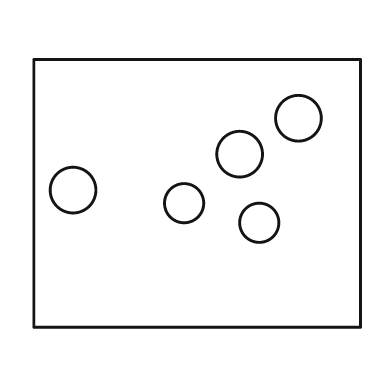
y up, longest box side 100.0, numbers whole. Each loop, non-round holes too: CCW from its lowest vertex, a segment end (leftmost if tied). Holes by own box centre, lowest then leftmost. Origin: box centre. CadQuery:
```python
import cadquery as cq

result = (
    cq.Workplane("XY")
    .moveTo(-50.0, -41.0)
    .lineTo(50.0, -41.0)
    .lineTo(50.0, 41.0)
    .lineTo(-50.0, 41.0)
    .close()
    .moveTo(19.0, -9.0)
    .circle(6.0)
    .moveTo(-4.0, -3.0)
    .circle(6.0)
    .moveTo(-38.0, 1.0)
    .circle(7.0)
    .moveTo(13.0, 12.0)
    .circle(7.0)
    .moveTo(31.0, 23.0)
    .circle(7.0)
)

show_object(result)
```